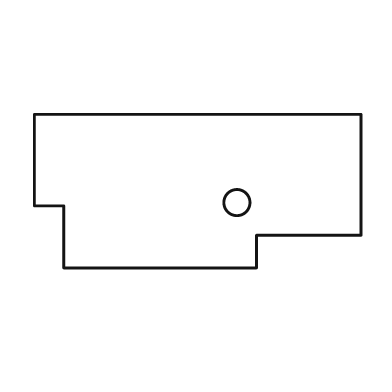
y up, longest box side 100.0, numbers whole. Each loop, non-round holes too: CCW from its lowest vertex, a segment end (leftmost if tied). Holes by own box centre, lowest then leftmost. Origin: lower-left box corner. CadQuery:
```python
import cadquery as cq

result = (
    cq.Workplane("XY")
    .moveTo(9.0, 0.0)
    .lineTo(68.0, 0.0)
    .lineTo(68.0, 10.0)
    .lineTo(100.0, 10.0)
    .lineTo(100.0, 47.0)
    .lineTo(0.0, 47.0)
    .lineTo(0.0, 19.0)
    .lineTo(9.0, 19.0)
    .close()
    .moveTo(62.0, 20.0)
    .circle(4.0)
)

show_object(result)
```